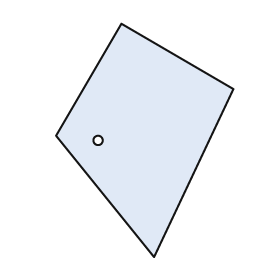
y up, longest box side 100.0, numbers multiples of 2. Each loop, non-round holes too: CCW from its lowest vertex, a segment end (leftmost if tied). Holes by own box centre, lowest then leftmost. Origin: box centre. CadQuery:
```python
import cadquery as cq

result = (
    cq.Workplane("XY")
    .moveTo(4.0, -50.0)
    .lineTo(38.0, 22.0)
    .lineTo(-10.0, 50.0)
    .lineTo(-38.0, 2.0)
    .close()
    .moveTo(-20.0, 0.0)
    .circle(2.0)
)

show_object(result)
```